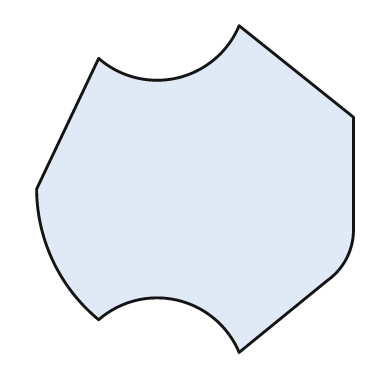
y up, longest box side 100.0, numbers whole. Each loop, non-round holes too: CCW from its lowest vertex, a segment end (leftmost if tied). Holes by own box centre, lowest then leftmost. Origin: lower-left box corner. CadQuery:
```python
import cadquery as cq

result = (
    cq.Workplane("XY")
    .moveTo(62.0, 0.0)
    .lineTo(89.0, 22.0)
    .threePointArc((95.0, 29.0), (97.0, 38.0))
    .lineTo(97.0, 72.0)
    .lineTo(62.0, 100.0)
    .threePointArc((43.0, 84.0), (19.0, 90.0))
    .lineTo(0.0, 50.0)
    .threePointArc((5.0, 28.0), (19.0, 10.0))
    .threePointArc((43.0, 16.0), (62.0, 0.0))
    .close()
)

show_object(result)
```